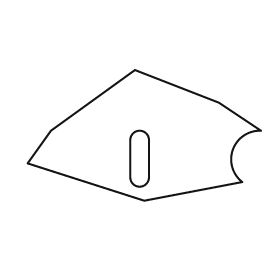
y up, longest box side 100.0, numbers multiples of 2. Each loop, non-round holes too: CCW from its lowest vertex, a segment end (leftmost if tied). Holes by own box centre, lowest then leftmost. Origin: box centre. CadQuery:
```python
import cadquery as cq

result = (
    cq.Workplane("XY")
    .moveTo(0.0, -28.0)
    .lineTo(42.0, -20.0)
    .threePointArc((38.0, -6.0), (50.0, 2.0))
    .lineTo(32.0, 14.0)
    .lineTo(-4.0, 28.0)
    .lineTo(-40.0, 2.0)
    .lineTo(-50.0, -12.0)
    .close()
    .moveTo(-6.0, -18.0)
    .threePointArc((-2.0, -22.0), (2.0, -18.0))
    .lineTo(2.0, -2.0)
    .threePointArc((-2.0, 2.0), (-6.0, -2.0))
    .close()
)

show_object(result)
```